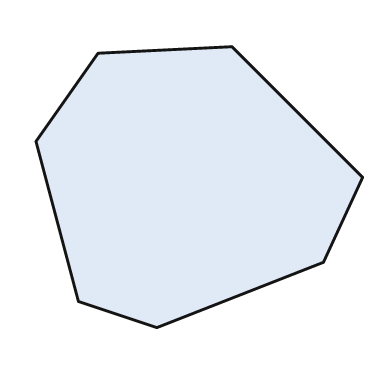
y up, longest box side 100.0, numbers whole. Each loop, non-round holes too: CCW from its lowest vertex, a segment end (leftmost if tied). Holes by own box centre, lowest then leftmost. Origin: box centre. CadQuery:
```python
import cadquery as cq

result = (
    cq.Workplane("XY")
    .moveTo(-13.0, -43.0)
    .lineTo(38.0, -23.0)
    .lineTo(50.0, 3.0)
    .lineTo(10.0, 43.0)
    .lineTo(-31.0, 41.0)
    .lineTo(-50.0, 14.0)
    .lineTo(-37.0, -35.0)
    .close()
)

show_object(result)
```